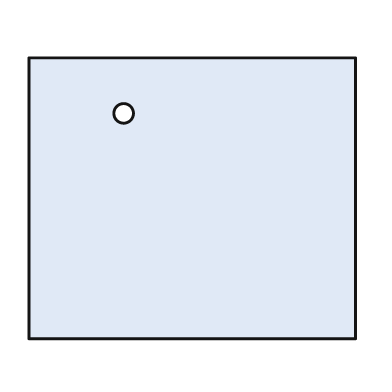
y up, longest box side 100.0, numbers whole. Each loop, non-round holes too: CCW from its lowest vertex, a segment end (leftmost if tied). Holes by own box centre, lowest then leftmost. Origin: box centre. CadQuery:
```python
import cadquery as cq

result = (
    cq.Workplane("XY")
    .moveTo(-50.0, -43.0)
    .lineTo(50.0, -43.0)
    .lineTo(50.0, 43.0)
    .lineTo(-50.0, 43.0)
    .close()
    .moveTo(-21.0, 26.0)
    .circle(3.0)
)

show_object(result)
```